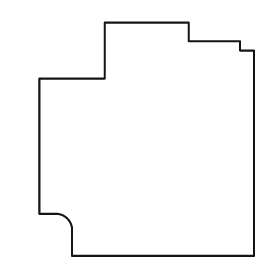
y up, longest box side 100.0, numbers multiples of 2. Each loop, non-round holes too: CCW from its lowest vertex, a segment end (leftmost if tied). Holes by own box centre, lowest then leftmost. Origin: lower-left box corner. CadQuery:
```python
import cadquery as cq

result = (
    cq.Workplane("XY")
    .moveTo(14.0, 0.0)
    .lineTo(92.0, 0.0)
    .lineTo(92.0, 88.0)
    .lineTo(86.0, 88.0)
    .lineTo(86.0, 92.0)
    .lineTo(64.0, 92.0)
    .lineTo(64.0, 100.0)
    .lineTo(28.0, 100.0)
    .lineTo(28.0, 76.0)
    .lineTo(0.0, 76.0)
    .lineTo(0.0, 18.0)
    .lineTo(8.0, 18.0)
    .threePointArc((12.0, 16.0), (14.0, 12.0))
    .close()
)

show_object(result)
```